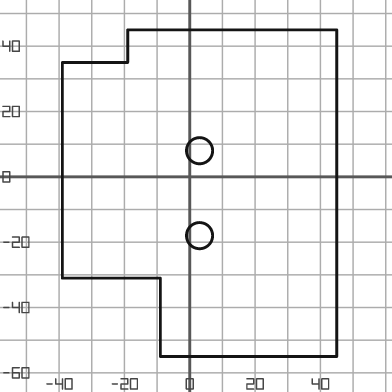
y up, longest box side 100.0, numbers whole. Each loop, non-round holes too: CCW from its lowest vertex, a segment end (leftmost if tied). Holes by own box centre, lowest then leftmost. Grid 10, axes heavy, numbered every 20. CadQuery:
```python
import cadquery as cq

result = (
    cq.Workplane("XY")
    .moveTo(-9.0, -55.0)
    .lineTo(45.0, -55.0)
    .lineTo(45.0, 45.0)
    .lineTo(-19.0, 45.0)
    .lineTo(-19.0, 35.0)
    .lineTo(-39.0, 35.0)
    .lineTo(-39.0, -31.0)
    .lineTo(-9.0, -31.0)
    .close()
    .moveTo(3.0, -18.0)
    .circle(4.0)
    .moveTo(3.0, 8.0)
    .circle(4.0)
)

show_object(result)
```